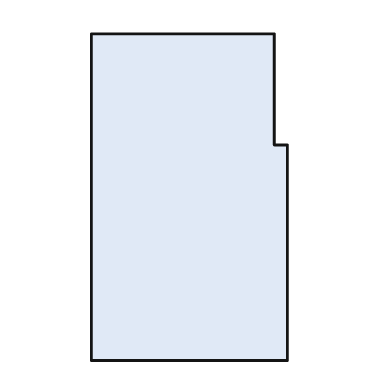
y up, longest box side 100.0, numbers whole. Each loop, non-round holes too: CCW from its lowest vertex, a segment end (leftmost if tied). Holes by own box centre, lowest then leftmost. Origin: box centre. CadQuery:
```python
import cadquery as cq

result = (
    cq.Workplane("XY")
    .moveTo(-30.0, -50.0)
    .lineTo(30.0, -50.0)
    .lineTo(30.0, 16.0)
    .lineTo(26.0, 16.0)
    .lineTo(26.0, 50.0)
    .lineTo(-30.0, 50.0)
    .close()
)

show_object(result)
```